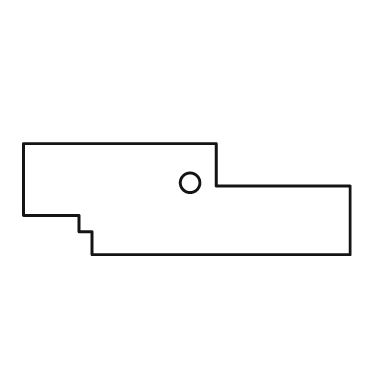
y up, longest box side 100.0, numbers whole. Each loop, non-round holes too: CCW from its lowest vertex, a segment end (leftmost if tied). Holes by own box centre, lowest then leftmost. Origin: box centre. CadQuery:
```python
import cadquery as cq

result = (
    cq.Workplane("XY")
    .moveTo(-29.0, -17.0)
    .lineTo(50.0, -17.0)
    .lineTo(50.0, 4.0)
    .lineTo(9.0, 4.0)
    .lineTo(9.0, 17.0)
    .lineTo(-50.0, 17.0)
    .lineTo(-50.0, -5.0)
    .lineTo(-33.0, -5.0)
    .lineTo(-33.0, -10.0)
    .lineTo(-29.0, -10.0)
    .close()
    .moveTo(1.0, 5.0)
    .circle(3.0)
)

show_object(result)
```